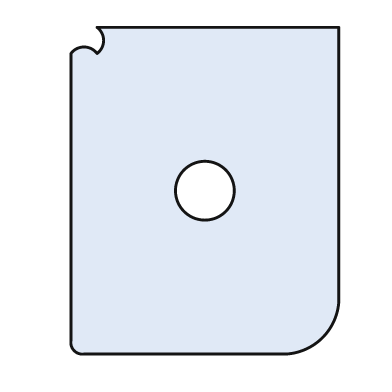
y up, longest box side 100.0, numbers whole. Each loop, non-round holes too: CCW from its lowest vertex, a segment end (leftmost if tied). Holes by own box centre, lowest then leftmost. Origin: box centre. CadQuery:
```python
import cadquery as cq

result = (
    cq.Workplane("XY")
    .moveTo(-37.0, -50.0)
    .lineTo(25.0, -50.0)
    .threePointArc((36.0, -45.0), (41.0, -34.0))
    .lineTo(41.0, 50.0)
    .lineTo(-33.0, 50.0)
    .threePointArc((-31.0, 46.0), (-33.0, 42.0))
    .threePointArc((-37.0, 44.0), (-41.0, 42.0))
    .lineTo(-41.0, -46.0)
    .threePointArc((-40.0, -49.0), (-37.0, -50.0))
    .close()
    .moveTo(0.0, 0.0)
    .circle(9.0)
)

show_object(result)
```